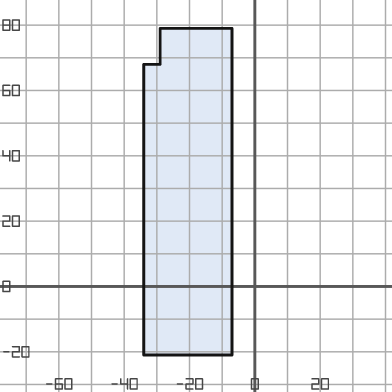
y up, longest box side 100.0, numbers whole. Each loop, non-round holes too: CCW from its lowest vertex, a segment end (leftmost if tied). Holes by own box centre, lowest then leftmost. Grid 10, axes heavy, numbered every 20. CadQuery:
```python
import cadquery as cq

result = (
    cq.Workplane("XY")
    .moveTo(-34.0, -21.0)
    .lineTo(-7.0, -21.0)
    .lineTo(-7.0, 79.0)
    .lineTo(-29.0, 79.0)
    .lineTo(-29.0, 68.0)
    .lineTo(-34.0, 68.0)
    .close()
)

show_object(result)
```